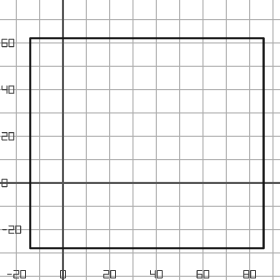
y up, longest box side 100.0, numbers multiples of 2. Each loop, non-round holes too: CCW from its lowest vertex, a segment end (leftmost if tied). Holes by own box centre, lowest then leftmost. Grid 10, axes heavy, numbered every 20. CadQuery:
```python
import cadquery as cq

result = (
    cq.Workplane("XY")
    .moveTo(-14.0, -28.0)
    .lineTo(86.0, -28.0)
    .lineTo(86.0, 62.0)
    .lineTo(-14.0, 62.0)
    .close()
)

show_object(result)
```